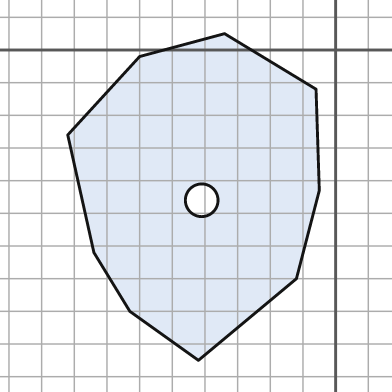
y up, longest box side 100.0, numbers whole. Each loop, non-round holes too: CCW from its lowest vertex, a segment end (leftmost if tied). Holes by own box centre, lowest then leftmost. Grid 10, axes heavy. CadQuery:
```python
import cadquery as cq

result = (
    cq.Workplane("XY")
    .moveTo(-42.0, -95.0)
    .lineTo(-12.0, -70.0)
    .lineTo(-5.0, -43.0)
    .lineTo(-6.0, -12.0)
    .lineTo(-34.0, 5.0)
    .lineTo(-60.0, -2.0)
    .lineTo(-82.0, -26.0)
    .lineTo(-74.0, -62.0)
    .lineTo(-63.0, -80.0)
    .close()
    .moveTo(-41.0, -46.0)
    .circle(5.0)
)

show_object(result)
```